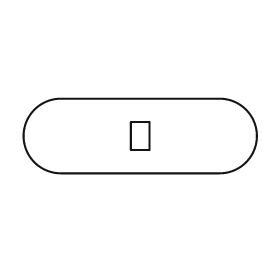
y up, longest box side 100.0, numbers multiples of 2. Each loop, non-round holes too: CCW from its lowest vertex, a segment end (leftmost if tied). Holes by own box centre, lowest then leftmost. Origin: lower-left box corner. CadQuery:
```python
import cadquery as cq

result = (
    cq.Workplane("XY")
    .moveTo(16.0, 0.0)
    .lineTo(84.0, 0.0)
    .threePointArc((100.0, 16.0), (84.0, 32.0))
    .lineTo(16.0, 32.0)
    .threePointArc((0.0, 16.0), (16.0, 0.0))
    .close()
    .moveTo(46.0, 10.0)
    .lineTo(54.0, 10.0)
    .lineTo(54.0, 22.0)
    .lineTo(46.0, 22.0)
    .close()
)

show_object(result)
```